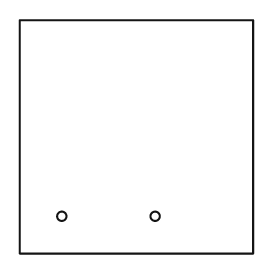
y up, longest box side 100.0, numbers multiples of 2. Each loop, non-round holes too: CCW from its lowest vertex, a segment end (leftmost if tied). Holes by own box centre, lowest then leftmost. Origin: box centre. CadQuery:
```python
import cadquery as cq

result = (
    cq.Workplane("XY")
    .moveTo(-50.0, -50.0)
    .lineTo(50.0, -50.0)
    .lineTo(50.0, 50.0)
    .lineTo(-50.0, 50.0)
    .close()
    .moveTo(-32.0, -34.0)
    .circle(2.0)
    .moveTo(8.0, -34.0)
    .circle(2.0)
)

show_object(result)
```